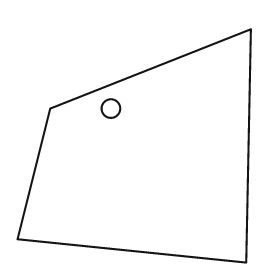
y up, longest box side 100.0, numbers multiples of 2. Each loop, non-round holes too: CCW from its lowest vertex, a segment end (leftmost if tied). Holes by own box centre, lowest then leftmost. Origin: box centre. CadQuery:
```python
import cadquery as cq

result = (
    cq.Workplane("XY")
    .moveTo(48.0, -50.0)
    .lineTo(50.0, 50.0)
    .lineTo(-36.0, 16.0)
    .lineTo(-50.0, -40.0)
    .close()
    .moveTo(-10.0, 16.0)
    .circle(4.0)
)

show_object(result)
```